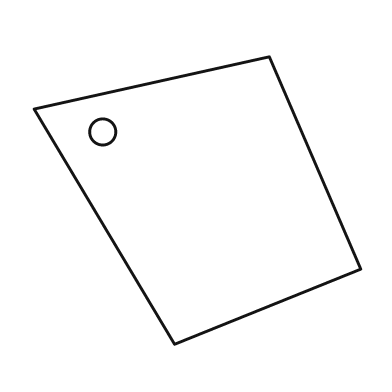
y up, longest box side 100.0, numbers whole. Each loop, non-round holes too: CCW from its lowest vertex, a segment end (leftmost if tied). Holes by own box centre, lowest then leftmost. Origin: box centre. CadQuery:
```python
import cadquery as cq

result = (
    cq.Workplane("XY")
    .moveTo(-7.0, -44.0)
    .lineTo(50.0, -21.0)
    .lineTo(22.0, 44.0)
    .lineTo(-50.0, 28.0)
    .close()
    .moveTo(-29.0, 21.0)
    .circle(4.0)
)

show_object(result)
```